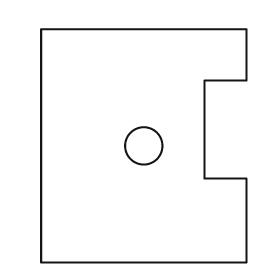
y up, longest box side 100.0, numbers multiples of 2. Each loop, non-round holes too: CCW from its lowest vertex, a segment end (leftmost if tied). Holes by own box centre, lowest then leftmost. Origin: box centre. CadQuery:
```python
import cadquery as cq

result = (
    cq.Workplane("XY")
    .moveTo(-44.0, -50.0)
    .lineTo(44.0, -50.0)
    .lineTo(44.0, -14.0)
    .lineTo(26.0, -14.0)
    .lineTo(26.0, 28.0)
    .lineTo(44.0, 28.0)
    .lineTo(44.0, 50.0)
    .lineTo(-44.0, 50.0)
    .close()
    .moveTo(0.0, 0.0)
    .circle(8.0)
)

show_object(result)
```